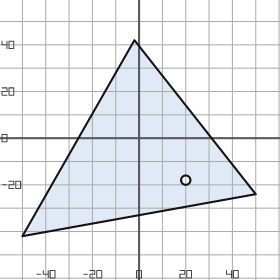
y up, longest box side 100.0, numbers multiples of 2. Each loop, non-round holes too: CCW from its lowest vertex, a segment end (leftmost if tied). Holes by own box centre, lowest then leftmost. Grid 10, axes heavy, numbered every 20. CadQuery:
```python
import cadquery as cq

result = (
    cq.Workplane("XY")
    .moveTo(-50.0, -42.0)
    .lineTo(50.0, -24.0)
    .lineTo(-2.0, 42.0)
    .close()
    .moveTo(20.0, -18.0)
    .circle(2.0)
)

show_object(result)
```